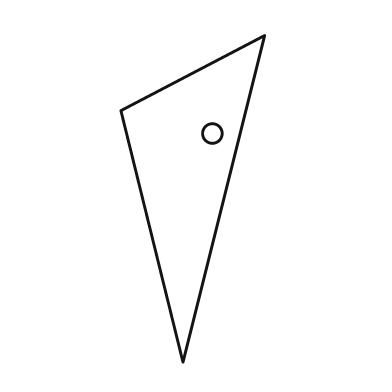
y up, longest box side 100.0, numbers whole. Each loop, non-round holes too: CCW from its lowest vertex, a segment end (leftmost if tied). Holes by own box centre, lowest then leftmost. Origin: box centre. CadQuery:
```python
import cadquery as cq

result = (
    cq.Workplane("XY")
    .moveTo(-3.0, -50.0)
    .lineTo(22.0, 50.0)
    .lineTo(-22.0, 27.0)
    .close()
    .moveTo(6.0, 20.0)
    .circle(3.0)
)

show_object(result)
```